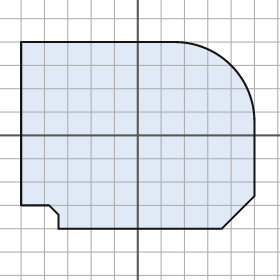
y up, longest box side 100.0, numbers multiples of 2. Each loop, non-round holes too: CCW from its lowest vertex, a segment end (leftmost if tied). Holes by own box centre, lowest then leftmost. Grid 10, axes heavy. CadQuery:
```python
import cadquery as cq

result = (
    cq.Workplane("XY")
    .moveTo(-34.0, -40.0)
    .lineTo(36.0, -40.0)
    .lineTo(50.0, -26.0)
    .lineTo(50.0, 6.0)
    .threePointArc((40.0, 30.0), (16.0, 40.0))
    .lineTo(-50.0, 40.0)
    .lineTo(-50.0, -30.0)
    .lineTo(-38.0, -30.0)
    .lineTo(-34.0, -34.0)
    .close()
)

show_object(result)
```